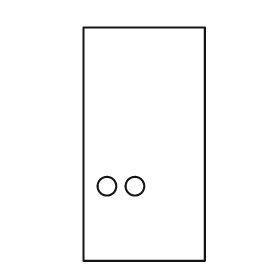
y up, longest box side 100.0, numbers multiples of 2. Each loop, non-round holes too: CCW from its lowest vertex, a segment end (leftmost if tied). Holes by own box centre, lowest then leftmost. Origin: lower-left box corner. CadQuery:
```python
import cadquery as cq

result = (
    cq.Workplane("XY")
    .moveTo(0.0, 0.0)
    .lineTo(52.0, 0.0)
    .lineTo(52.0, 100.0)
    .lineTo(0.0, 100.0)
    .close()
    .moveTo(10.0, 32.0)
    .circle(4.0)
    .moveTo(22.0, 32.0)
    .circle(4.0)
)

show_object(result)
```